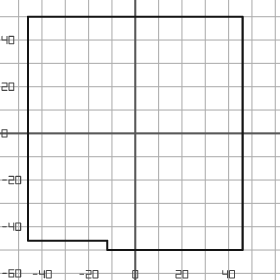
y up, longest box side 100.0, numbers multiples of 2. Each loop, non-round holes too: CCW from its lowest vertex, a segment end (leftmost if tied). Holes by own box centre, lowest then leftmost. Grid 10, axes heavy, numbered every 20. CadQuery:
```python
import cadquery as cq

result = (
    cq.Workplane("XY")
    .moveTo(-12.0, -50.0)
    .lineTo(46.0, -50.0)
    .lineTo(46.0, 50.0)
    .lineTo(-46.0, 50.0)
    .lineTo(-46.0, -46.0)
    .lineTo(-12.0, -46.0)
    .close()
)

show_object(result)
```